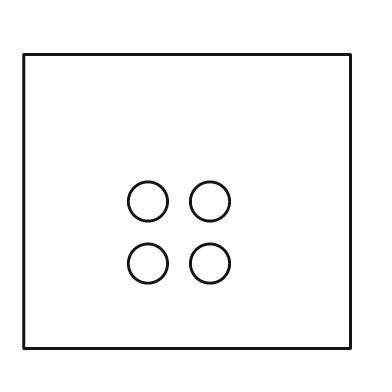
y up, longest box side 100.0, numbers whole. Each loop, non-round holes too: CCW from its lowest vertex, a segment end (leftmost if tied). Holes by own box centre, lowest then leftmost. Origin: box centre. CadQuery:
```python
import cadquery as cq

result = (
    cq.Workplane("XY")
    .moveTo(-50.0, -45.0)
    .lineTo(50.0, -45.0)
    .lineTo(50.0, 45.0)
    .lineTo(-50.0, 45.0)
    .close()
    .moveTo(-12.0, -19.0)
    .circle(6.0)
    .moveTo(7.0, -19.0)
    .circle(6.0)
    .moveTo(-12.0, 0.0)
    .circle(6.0)
    .moveTo(7.0, 0.0)
    .circle(6.0)
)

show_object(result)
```